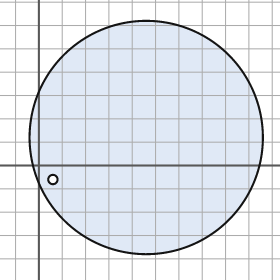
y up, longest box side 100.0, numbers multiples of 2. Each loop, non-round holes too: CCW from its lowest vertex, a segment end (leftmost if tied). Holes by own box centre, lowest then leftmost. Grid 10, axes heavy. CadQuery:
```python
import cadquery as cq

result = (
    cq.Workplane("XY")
    .moveTo(46.0, 12.0)
    .circle(50.0)
    .moveTo(6.0, -6.0)
    .circle(2.0)
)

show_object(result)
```